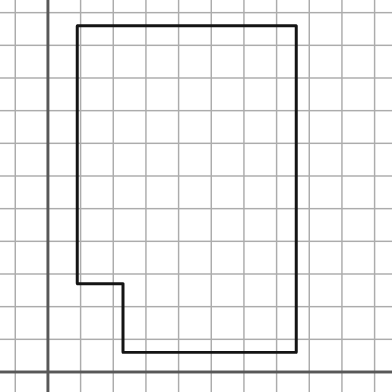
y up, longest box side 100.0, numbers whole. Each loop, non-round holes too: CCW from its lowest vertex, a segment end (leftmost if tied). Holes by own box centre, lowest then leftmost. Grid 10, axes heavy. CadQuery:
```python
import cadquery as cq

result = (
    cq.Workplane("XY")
    .moveTo(23.0, 6.0)
    .lineTo(76.0, 6.0)
    .lineTo(76.0, 106.0)
    .lineTo(9.0, 106.0)
    .lineTo(9.0, 27.0)
    .lineTo(23.0, 27.0)
    .close()
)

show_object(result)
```